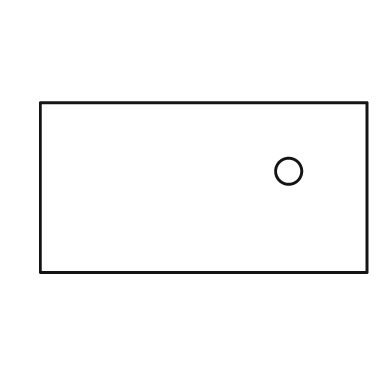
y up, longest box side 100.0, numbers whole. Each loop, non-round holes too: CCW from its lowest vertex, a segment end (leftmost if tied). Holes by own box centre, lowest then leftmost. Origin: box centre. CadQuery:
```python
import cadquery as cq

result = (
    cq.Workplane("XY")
    .moveTo(-50.0, -26.0)
    .lineTo(50.0, -26.0)
    .lineTo(50.0, 26.0)
    .lineTo(-50.0, 26.0)
    .close()
    .moveTo(26.0, 5.0)
    .circle(4.0)
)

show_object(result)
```